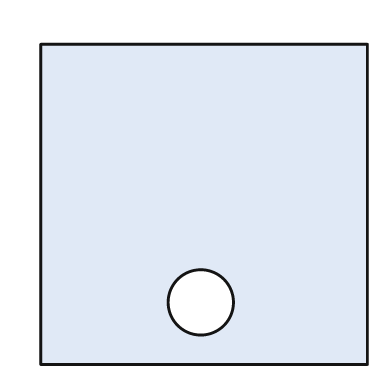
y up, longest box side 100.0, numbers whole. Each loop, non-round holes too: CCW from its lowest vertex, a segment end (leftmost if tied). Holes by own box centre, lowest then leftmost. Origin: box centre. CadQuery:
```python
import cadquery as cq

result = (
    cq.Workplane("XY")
    .moveTo(-50.0, -49.0)
    .lineTo(50.0, -49.0)
    .lineTo(50.0, 49.0)
    .lineTo(-50.0, 49.0)
    .close()
    .moveTo(-1.0, -30.0)
    .circle(10.0)
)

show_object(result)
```